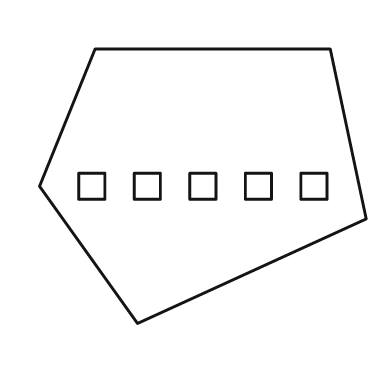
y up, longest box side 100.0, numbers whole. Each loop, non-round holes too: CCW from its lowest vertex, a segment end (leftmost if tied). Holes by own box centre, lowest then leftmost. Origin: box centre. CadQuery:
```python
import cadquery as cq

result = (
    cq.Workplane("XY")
    .moveTo(-20.0, -42.0)
    .lineTo(50.0, -10.0)
    .lineTo(39.0, 42.0)
    .lineTo(-33.0, 42.0)
    .lineTo(-50.0, 0.0)
    .close()
    .moveTo(-38.0, -4.0)
    .lineTo(-30.0, -4.0)
    .lineTo(-30.0, 4.0)
    .lineTo(-38.0, 4.0)
    .close()
    .moveTo(-21.0, -4.0)
    .lineTo(-13.0, -4.0)
    .lineTo(-13.0, 4.0)
    .lineTo(-21.0, 4.0)
    .close()
    .moveTo(-4.0, -4.0)
    .lineTo(4.0, -4.0)
    .lineTo(4.0, 4.0)
    .lineTo(-4.0, 4.0)
    .close()
    .moveTo(13.0, -4.0)
    .lineTo(21.0, -4.0)
    .lineTo(21.0, 4.0)
    .lineTo(13.0, 4.0)
    .close()
    .moveTo(30.0, -4.0)
    .lineTo(38.0, -4.0)
    .lineTo(38.0, 4.0)
    .lineTo(30.0, 4.0)
    .close()
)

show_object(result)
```